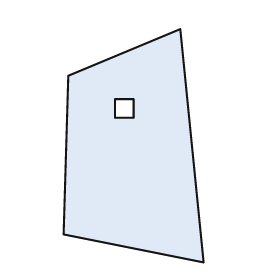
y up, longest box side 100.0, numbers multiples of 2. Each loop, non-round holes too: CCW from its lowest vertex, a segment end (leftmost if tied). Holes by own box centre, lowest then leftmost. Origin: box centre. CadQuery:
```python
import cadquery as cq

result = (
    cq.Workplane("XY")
    .moveTo(30.0, -50.0)
    .lineTo(20.0, 50.0)
    .lineTo(-28.0, 30.0)
    .lineTo(-30.0, -38.0)
    .close()
    .moveTo(-8.0, 12.0)
    .lineTo(0.0, 12.0)
    .lineTo(0.0, 20.0)
    .lineTo(-8.0, 20.0)
    .close()
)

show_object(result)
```